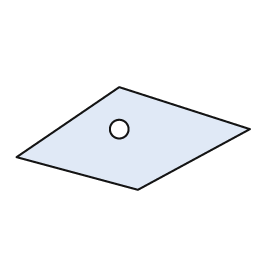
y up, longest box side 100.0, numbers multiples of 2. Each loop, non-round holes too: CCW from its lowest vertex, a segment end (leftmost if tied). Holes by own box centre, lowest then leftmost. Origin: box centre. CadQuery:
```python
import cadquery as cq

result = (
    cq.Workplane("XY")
    .moveTo(2.0, -22.0)
    .lineTo(50.0, 4.0)
    .lineTo(-6.0, 22.0)
    .lineTo(-50.0, -8.0)
    .close()
    .moveTo(-6.0, 4.0)
    .circle(4.0)
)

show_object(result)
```